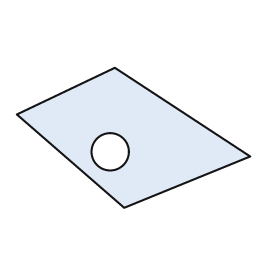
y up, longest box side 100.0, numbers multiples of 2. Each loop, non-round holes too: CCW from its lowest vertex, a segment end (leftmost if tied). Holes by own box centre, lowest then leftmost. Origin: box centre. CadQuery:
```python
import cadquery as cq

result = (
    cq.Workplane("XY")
    .moveTo(-4.0, -30.0)
    .lineTo(50.0, -8.0)
    .lineTo(-8.0, 30.0)
    .lineTo(-50.0, 10.0)
    .close()
    .moveTo(-10.0, -6.0)
    .circle(8.0)
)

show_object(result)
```